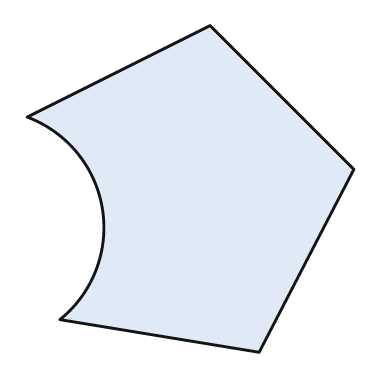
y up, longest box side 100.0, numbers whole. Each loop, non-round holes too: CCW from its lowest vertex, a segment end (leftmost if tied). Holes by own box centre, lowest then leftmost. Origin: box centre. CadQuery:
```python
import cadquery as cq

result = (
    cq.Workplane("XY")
    .moveTo(21.0, -50.0)
    .lineTo(50.0, 6.0)
    .lineTo(6.0, 50.0)
    .lineTo(-50.0, 22.0)
    .threePointArc((-27.0, -6.0), (-40.0, -40.0))
    .close()
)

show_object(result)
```